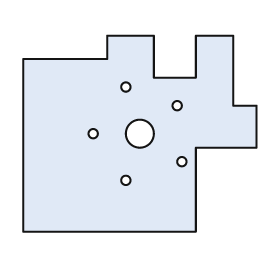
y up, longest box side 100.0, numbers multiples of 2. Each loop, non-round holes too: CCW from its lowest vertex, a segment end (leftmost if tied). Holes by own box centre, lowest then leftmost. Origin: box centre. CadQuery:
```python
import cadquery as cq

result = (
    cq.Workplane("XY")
    .moveTo(-50.0, -42.0)
    .lineTo(24.0, -42.0)
    .lineTo(24.0, -6.0)
    .lineTo(50.0, -6.0)
    .lineTo(50.0, 12.0)
    .lineTo(40.0, 12.0)
    .lineTo(40.0, 42.0)
    .lineTo(24.0, 42.0)
    .lineTo(24.0, 24.0)
    .lineTo(6.0, 24.0)
    .lineTo(6.0, 42.0)
    .lineTo(-14.0, 42.0)
    .lineTo(-14.0, 32.0)
    .lineTo(-50.0, 32.0)
    .close()
    .moveTo(-6.0, -20.0)
    .circle(2.0)
    .moveTo(18.0, -12.0)
    .circle(2.0)
    .moveTo(-20.0, 0.0)
    .circle(2.0)
    .moveTo(0.0, 0.0)
    .circle(6.0)
    .moveTo(16.0, 12.0)
    .circle(2.0)
    .moveTo(-6.0, 20.0)
    .circle(2.0)
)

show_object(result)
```